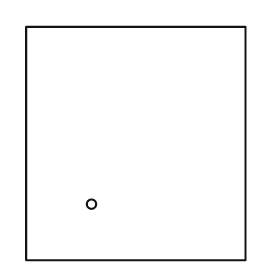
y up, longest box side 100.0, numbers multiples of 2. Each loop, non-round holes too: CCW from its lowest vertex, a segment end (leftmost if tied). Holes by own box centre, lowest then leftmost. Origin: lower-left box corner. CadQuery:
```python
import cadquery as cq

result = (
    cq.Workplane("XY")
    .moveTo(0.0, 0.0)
    .lineTo(94.0, 0.0)
    .lineTo(94.0, 100.0)
    .lineTo(0.0, 100.0)
    .close()
    .moveTo(28.0, 24.0)
    .circle(2.0)
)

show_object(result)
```